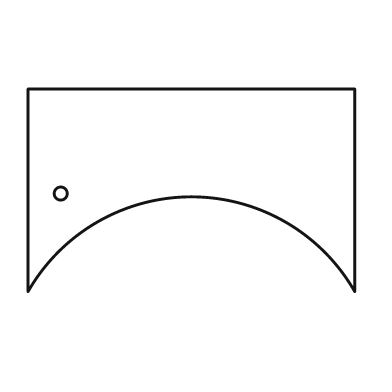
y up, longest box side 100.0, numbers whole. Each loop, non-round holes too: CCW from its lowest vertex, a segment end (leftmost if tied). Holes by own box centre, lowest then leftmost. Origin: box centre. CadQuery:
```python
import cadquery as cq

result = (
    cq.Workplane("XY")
    .moveTo(-50.0, -31.0)
    .threePointArc((0.0, -2.0), (50.0, -31.0))
    .lineTo(50.0, 31.0)
    .lineTo(-50.0, 31.0)
    .close()
    .moveTo(-40.0, -1.0)
    .circle(2.0)
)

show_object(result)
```